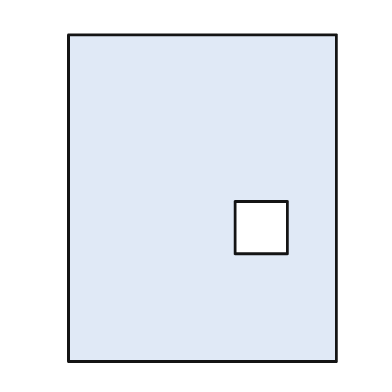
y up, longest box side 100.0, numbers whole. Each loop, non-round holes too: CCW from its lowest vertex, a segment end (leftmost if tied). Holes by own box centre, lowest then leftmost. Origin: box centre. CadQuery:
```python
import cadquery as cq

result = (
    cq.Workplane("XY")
    .moveTo(-41.0, -50.0)
    .lineTo(41.0, -50.0)
    .lineTo(41.0, 50.0)
    .lineTo(-41.0, 50.0)
    .close()
    .moveTo(10.0, -17.0)
    .lineTo(26.0, -17.0)
    .lineTo(26.0, -1.0)
    .lineTo(10.0, -1.0)
    .close()
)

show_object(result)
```